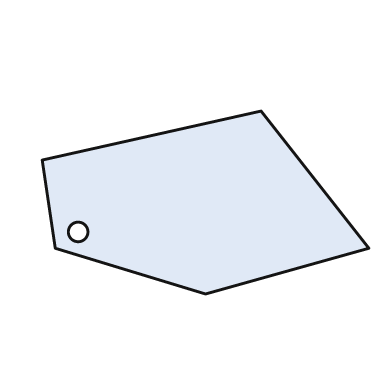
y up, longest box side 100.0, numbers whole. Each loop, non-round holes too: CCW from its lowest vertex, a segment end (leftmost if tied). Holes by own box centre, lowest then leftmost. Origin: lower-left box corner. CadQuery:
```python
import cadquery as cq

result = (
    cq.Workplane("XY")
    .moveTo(50.0, 0.0)
    .lineTo(100.0, 14.0)
    .lineTo(67.0, 56.0)
    .lineTo(0.0, 41.0)
    .lineTo(4.0, 14.0)
    .close()
    .moveTo(11.0, 19.0)
    .circle(3.0)
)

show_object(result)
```